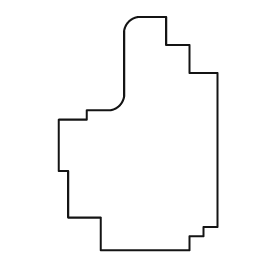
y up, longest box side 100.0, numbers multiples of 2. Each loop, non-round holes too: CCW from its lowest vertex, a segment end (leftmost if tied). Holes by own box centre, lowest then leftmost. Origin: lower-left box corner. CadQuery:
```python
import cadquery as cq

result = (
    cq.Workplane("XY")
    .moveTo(18.0, 0.0)
    .lineTo(56.0, 0.0)
    .lineTo(56.0, 6.0)
    .lineTo(62.0, 6.0)
    .lineTo(62.0, 10.0)
    .lineTo(68.0, 10.0)
    .lineTo(68.0, 76.0)
    .lineTo(56.0, 76.0)
    .lineTo(56.0, 88.0)
    .lineTo(46.0, 88.0)
    .lineTo(46.0, 100.0)
    .lineTo(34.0, 100.0)
    .threePointArc((30.0, 98.0), (28.0, 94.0))
    .lineTo(28.0, 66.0)
    .threePointArc((26.0, 62.0), (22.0, 60.0))
    .lineTo(12.0, 60.0)
    .lineTo(12.0, 56.0)
    .lineTo(0.0, 56.0)
    .lineTo(0.0, 34.0)
    .lineTo(4.0, 34.0)
    .lineTo(4.0, 14.0)
    .lineTo(18.0, 14.0)
    .close()
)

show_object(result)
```